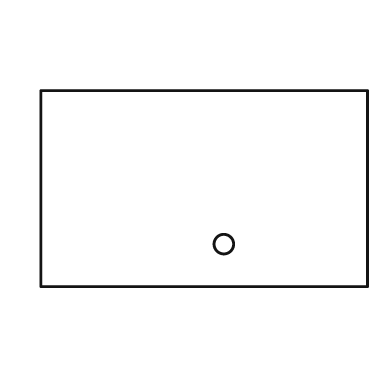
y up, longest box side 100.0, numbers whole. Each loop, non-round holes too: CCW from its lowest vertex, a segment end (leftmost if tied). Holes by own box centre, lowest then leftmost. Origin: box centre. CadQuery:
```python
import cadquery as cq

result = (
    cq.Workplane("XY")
    .moveTo(-50.0, -30.0)
    .lineTo(50.0, -30.0)
    .lineTo(50.0, 30.0)
    .lineTo(-50.0, 30.0)
    .close()
    .moveTo(6.0, -17.0)
    .circle(3.0)
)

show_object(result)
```